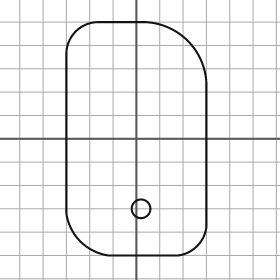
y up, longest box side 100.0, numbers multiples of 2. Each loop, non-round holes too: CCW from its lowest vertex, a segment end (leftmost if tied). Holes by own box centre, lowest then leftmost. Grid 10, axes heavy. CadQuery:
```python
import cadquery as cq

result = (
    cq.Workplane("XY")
    .moveTo(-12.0, -50.0)
    .lineTo(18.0, -50.0)
    .threePointArc((26.0, -46.0), (30.0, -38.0))
    .lineTo(30.0, 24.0)
    .threePointArc((22.0, 42.0), (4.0, 50.0))
    .lineTo(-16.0, 50.0)
    .threePointArc((-26.0, 46.0), (-30.0, 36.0))
    .lineTo(-30.0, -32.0)
    .threePointArc((-24.0, -44.0), (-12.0, -50.0))
    .close()
    .moveTo(2.0, -30.0)
    .circle(4.0)
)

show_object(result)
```